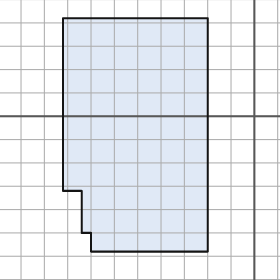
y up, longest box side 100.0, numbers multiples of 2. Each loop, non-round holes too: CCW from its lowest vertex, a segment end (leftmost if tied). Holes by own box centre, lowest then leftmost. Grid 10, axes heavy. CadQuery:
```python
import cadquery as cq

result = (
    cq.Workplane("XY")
    .moveTo(-70.0, -58.0)
    .lineTo(-20.0, -58.0)
    .lineTo(-20.0, 42.0)
    .lineTo(-82.0, 42.0)
    .lineTo(-82.0, -32.0)
    .lineTo(-74.0, -32.0)
    .lineTo(-74.0, -50.0)
    .lineTo(-70.0, -50.0)
    .close()
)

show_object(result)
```